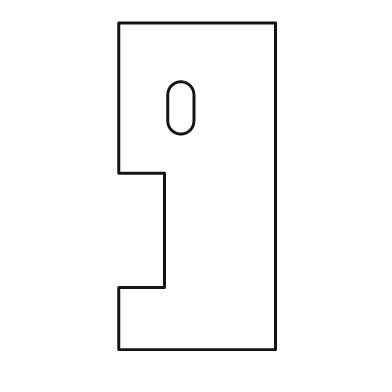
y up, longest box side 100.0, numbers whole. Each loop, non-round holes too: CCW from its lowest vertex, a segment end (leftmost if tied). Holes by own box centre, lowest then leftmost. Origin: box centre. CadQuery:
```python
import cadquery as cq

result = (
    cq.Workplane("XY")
    .moveTo(-24.0, -50.0)
    .lineTo(24.0, -50.0)
    .lineTo(24.0, 50.0)
    .lineTo(-24.0, 50.0)
    .lineTo(-24.0, 4.0)
    .lineTo(-10.0, 4.0)
    .lineTo(-10.0, -31.0)
    .lineTo(-24.0, -31.0)
    .close()
    .moveTo(-9.0, 20.0)
    .threePointArc((-5.0, 16.0), (-1.0, 20.0))
    .lineTo(-1.0, 28.0)
    .threePointArc((-5.0, 32.0), (-9.0, 28.0))
    .close()
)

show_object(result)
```